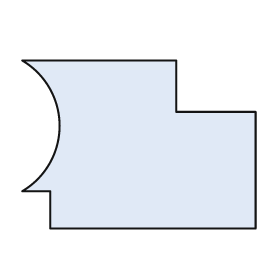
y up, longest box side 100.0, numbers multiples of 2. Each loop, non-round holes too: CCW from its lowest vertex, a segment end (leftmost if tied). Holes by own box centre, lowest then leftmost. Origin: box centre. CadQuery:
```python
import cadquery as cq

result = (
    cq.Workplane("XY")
    .moveTo(-38.0, -36.0)
    .lineTo(50.0, -36.0)
    .lineTo(50.0, 14.0)
    .lineTo(16.0, 14.0)
    .lineTo(16.0, 36.0)
    .lineTo(-50.0, 36.0)
    .threePointArc((-34.0, 8.0), (-50.0, -20.0))
    .lineTo(-38.0, -20.0)
    .close()
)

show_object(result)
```